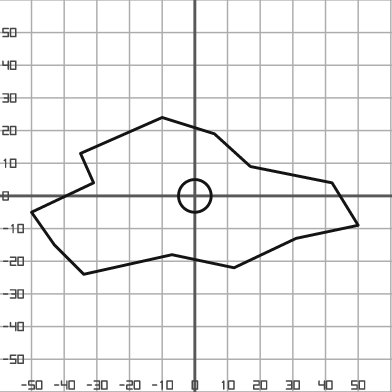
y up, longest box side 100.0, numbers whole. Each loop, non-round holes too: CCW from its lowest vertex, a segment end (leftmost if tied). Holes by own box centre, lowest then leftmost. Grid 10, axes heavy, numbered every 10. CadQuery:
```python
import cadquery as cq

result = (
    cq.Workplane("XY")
    .moveTo(-34.0, -24.0)
    .lineTo(-7.0, -18.0)
    .lineTo(12.0, -22.0)
    .lineTo(31.0, -13.0)
    .lineTo(50.0, -9.0)
    .lineTo(42.0, 4.0)
    .lineTo(17.0, 9.0)
    .lineTo(6.0, 19.0)
    .lineTo(-10.0, 24.0)
    .lineTo(-35.0, 13.0)
    .lineTo(-31.0, 4.0)
    .lineTo(-50.0, -5.0)
    .lineTo(-43.0, -15.0)
    .close()
    .moveTo(0.0, 0.0)
    .circle(5.0)
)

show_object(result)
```